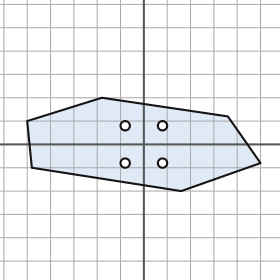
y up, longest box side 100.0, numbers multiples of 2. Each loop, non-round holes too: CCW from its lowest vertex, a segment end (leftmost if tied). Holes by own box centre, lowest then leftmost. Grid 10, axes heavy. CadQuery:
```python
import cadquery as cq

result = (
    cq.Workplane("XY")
    .moveTo(16.0, -20.0)
    .lineTo(50.0, -8.0)
    .lineTo(36.0, 12.0)
    .lineTo(-18.0, 20.0)
    .lineTo(-50.0, 10.0)
    .lineTo(-48.0, -10.0)
    .close()
    .moveTo(-8.0, -8.0)
    .circle(2.0)
    .moveTo(8.0, -8.0)
    .circle(2.0)
    .moveTo(-8.0, 8.0)
    .circle(2.0)
    .moveTo(8.0, 8.0)
    .circle(2.0)
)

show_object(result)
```